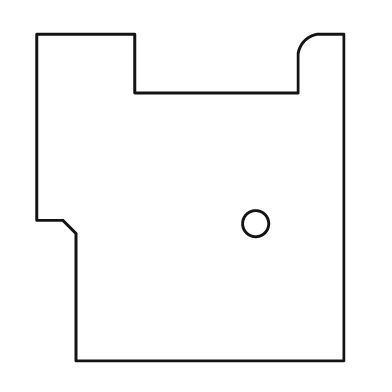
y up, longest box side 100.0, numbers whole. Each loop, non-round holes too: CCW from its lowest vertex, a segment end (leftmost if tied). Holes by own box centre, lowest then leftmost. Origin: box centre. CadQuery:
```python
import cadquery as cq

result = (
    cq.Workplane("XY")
    .moveTo(-35.0, -50.0)
    .lineTo(47.0, -50.0)
    .lineTo(47.0, 50.0)
    .lineTo(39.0, 50.0)
    .threePointArc((35.0, 48.0), (33.0, 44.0))
    .lineTo(33.0, 32.0)
    .lineTo(-17.0, 32.0)
    .lineTo(-17.0, 50.0)
    .lineTo(-47.0, 50.0)
    .lineTo(-47.0, -7.0)
    .lineTo(-39.0, -7.0)
    .lineTo(-35.0, -11.0)
    .close()
    .moveTo(20.0, -8.0)
    .circle(4.0)
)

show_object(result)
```